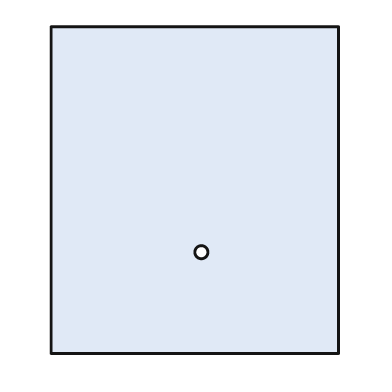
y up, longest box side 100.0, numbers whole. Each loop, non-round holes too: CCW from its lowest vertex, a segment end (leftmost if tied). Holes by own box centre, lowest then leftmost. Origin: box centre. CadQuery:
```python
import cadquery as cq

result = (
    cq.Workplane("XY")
    .moveTo(-44.0, -50.0)
    .lineTo(44.0, -50.0)
    .lineTo(44.0, 50.0)
    .lineTo(-44.0, 50.0)
    .close()
    .moveTo(2.0, -19.0)
    .circle(2.0)
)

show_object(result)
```